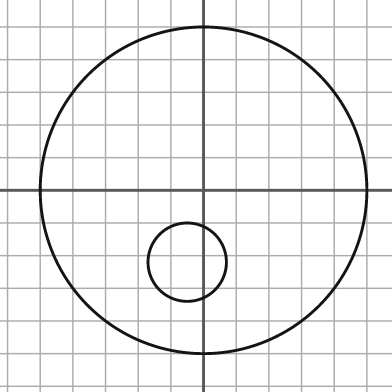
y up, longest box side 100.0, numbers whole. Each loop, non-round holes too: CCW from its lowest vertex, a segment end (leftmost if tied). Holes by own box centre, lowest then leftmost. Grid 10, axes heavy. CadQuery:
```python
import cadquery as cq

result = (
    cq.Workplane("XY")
    .moveTo(0.0, 0.0)
    .circle(50.0)
    .moveTo(-5.0, -22.0)
    .circle(12.0)
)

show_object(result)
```